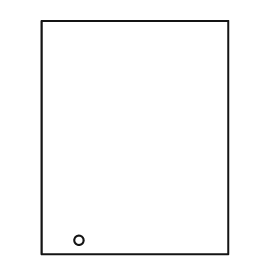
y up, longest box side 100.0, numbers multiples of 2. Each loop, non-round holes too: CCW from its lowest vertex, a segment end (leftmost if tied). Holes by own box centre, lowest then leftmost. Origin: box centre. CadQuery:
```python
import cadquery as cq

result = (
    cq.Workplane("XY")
    .moveTo(-40.0, -50.0)
    .lineTo(40.0, -50.0)
    .lineTo(40.0, 50.0)
    .lineTo(-40.0, 50.0)
    .close()
    .moveTo(-24.0, -44.0)
    .circle(2.0)
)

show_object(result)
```